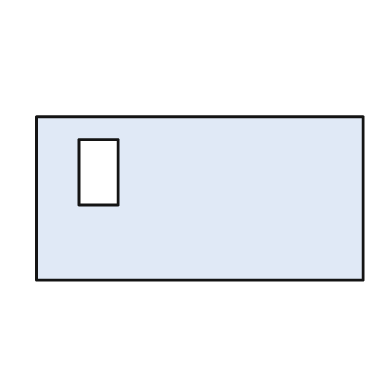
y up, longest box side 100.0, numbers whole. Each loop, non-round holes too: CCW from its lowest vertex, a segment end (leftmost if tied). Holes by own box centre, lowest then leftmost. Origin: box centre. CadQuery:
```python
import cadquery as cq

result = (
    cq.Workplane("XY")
    .moveTo(-50.0, -25.0)
    .lineTo(50.0, -25.0)
    .lineTo(50.0, 25.0)
    .lineTo(-50.0, 25.0)
    .close()
    .moveTo(-37.0, -2.0)
    .lineTo(-25.0, -2.0)
    .lineTo(-25.0, 18.0)
    .lineTo(-37.0, 18.0)
    .close()
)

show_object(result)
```